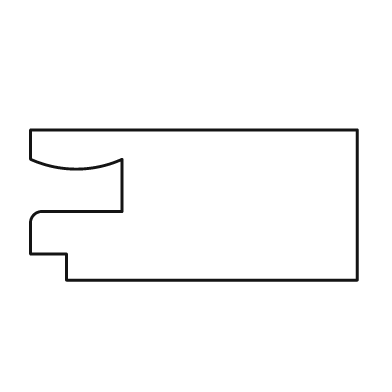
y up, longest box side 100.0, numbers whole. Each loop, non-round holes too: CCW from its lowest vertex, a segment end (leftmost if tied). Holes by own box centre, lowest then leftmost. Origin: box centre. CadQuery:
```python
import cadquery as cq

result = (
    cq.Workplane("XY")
    .moveTo(-39.0, -23.0)
    .lineTo(50.0, -23.0)
    .lineTo(50.0, 23.0)
    .lineTo(-50.0, 23.0)
    .lineTo(-50.0, 14.0)
    .threePointArc((-36.0, 11.0), (-22.0, 14.0))
    .lineTo(-22.0, -2.0)
    .lineTo(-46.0, -2.0)
    .threePointArc((-49.0, -3.0), (-50.0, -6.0))
    .lineTo(-50.0, -15.0)
    .lineTo(-39.0, -15.0)
    .close()
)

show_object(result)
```